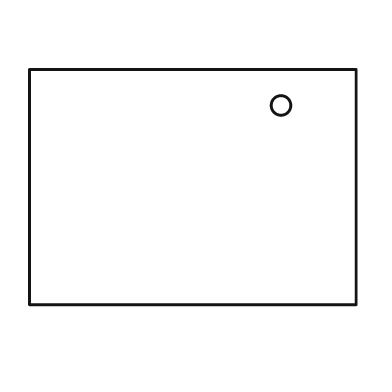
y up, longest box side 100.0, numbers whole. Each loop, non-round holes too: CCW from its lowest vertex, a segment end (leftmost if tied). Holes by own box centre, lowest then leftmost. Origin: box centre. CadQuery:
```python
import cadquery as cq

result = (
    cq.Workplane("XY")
    .moveTo(-50.0, -36.0)
    .lineTo(50.0, -36.0)
    .lineTo(50.0, 36.0)
    .lineTo(-50.0, 36.0)
    .close()
    .moveTo(27.0, 25.0)
    .circle(3.0)
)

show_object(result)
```